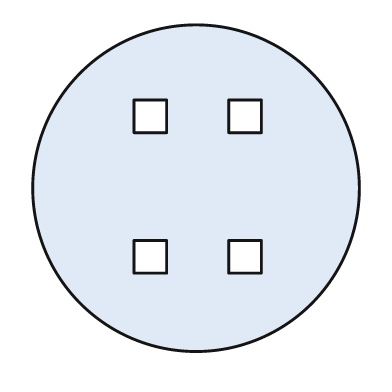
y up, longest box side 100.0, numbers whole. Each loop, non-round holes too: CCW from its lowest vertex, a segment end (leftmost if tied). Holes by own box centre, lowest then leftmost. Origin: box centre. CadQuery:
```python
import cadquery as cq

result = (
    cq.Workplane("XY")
    .moveTo(0.0, 0.0)
    .circle(50.0)
    .moveTo(-19.0, -26.0)
    .lineTo(-9.0, -26.0)
    .lineTo(-9.0, -16.0)
    .lineTo(-19.0, -16.0)
    .close()
    .moveTo(10.0, -26.0)
    .lineTo(20.0, -26.0)
    .lineTo(20.0, -16.0)
    .lineTo(10.0, -16.0)
    .close()
    .moveTo(-19.0, 17.0)
    .lineTo(-9.0, 17.0)
    .lineTo(-9.0, 27.0)
    .lineTo(-19.0, 27.0)
    .close()
    .moveTo(10.0, 17.0)
    .lineTo(20.0, 17.0)
    .lineTo(20.0, 27.0)
    .lineTo(10.0, 27.0)
    .close()
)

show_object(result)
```